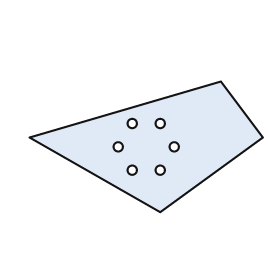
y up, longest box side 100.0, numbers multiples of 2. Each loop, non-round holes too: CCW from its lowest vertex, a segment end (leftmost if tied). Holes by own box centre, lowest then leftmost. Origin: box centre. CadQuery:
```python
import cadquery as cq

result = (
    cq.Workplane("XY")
    .moveTo(6.0, -28.0)
    .lineTo(50.0, 4.0)
    .lineTo(32.0, 28.0)
    .lineTo(-50.0, 4.0)
    .close()
    .moveTo(-6.0, -10.0)
    .circle(2.0)
    .moveTo(6.0, -10.0)
    .circle(2.0)
    .moveTo(-12.0, 0.0)
    .circle(2.0)
    .moveTo(12.0, 0.0)
    .circle(2.0)
    .moveTo(-6.0, 10.0)
    .circle(2.0)
    .moveTo(6.0, 10.0)
    .circle(2.0)
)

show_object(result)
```